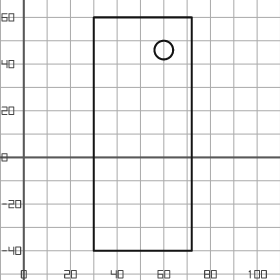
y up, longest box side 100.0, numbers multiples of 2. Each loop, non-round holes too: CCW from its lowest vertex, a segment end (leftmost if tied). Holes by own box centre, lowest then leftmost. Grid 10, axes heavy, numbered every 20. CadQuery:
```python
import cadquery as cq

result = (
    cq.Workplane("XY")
    .moveTo(30.0, -40.0)
    .lineTo(72.0, -40.0)
    .lineTo(72.0, 60.0)
    .lineTo(30.0, 60.0)
    .close()
    .moveTo(60.0, 46.0)
    .circle(4.0)
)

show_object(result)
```